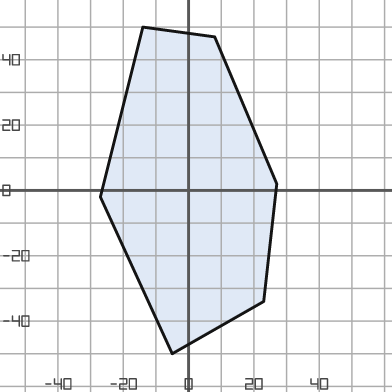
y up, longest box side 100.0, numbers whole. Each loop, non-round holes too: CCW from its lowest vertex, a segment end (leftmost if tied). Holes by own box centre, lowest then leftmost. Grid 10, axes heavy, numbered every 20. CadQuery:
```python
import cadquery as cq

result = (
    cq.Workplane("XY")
    .moveTo(-5.0, -50.0)
    .lineTo(23.0, -34.0)
    .lineTo(27.0, 2.0)
    .lineTo(8.0, 47.0)
    .lineTo(-14.0, 50.0)
    .lineTo(-27.0, -2.0)
    .close()
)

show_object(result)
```